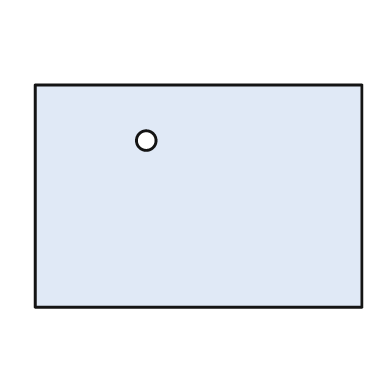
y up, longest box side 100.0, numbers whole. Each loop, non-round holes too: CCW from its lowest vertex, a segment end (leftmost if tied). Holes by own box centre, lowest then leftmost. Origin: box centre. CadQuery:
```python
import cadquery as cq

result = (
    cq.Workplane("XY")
    .moveTo(-50.0, -34.0)
    .lineTo(50.0, -34.0)
    .lineTo(50.0, 34.0)
    .lineTo(-50.0, 34.0)
    .close()
    .moveTo(-16.0, 17.0)
    .circle(3.0)
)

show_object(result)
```